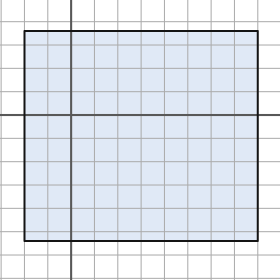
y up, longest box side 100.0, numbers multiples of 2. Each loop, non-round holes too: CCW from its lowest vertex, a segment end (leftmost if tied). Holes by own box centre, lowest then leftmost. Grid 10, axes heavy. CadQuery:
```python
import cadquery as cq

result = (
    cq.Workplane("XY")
    .moveTo(-20.0, -54.0)
    .lineTo(80.0, -54.0)
    .lineTo(80.0, 36.0)
    .lineTo(-20.0, 36.0)
    .close()
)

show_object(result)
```